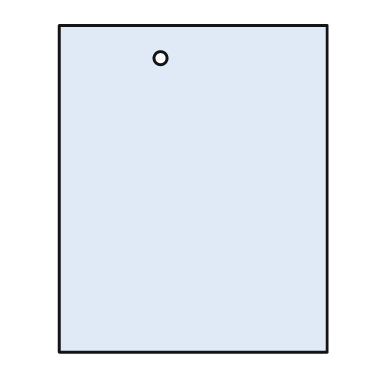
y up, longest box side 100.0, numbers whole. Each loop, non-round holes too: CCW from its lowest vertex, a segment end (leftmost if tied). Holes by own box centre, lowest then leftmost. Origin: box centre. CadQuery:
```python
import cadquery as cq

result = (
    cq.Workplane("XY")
    .moveTo(-41.0, -50.0)
    .lineTo(41.0, -50.0)
    .lineTo(41.0, 50.0)
    .lineTo(-41.0, 50.0)
    .close()
    .moveTo(-10.0, 40.0)
    .circle(2.0)
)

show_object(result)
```